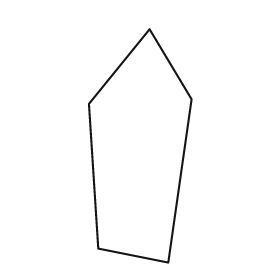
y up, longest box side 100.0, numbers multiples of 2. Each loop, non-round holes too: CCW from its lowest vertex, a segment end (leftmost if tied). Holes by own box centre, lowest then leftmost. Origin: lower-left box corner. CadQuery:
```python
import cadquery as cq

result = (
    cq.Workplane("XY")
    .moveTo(34.0, 0.0)
    .lineTo(44.0, 70.0)
    .lineTo(26.0, 100.0)
    .lineTo(0.0, 68.0)
    .lineTo(4.0, 6.0)
    .close()
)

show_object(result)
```